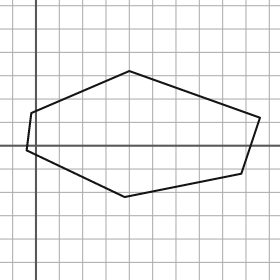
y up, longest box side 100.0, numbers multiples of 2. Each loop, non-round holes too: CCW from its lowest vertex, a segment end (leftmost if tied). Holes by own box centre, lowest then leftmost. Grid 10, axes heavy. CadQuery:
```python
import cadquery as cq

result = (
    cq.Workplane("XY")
    .moveTo(38.0, -22.0)
    .lineTo(88.0, -12.0)
    .lineTo(96.0, 12.0)
    .lineTo(40.0, 32.0)
    .lineTo(-2.0, 14.0)
    .lineTo(-4.0, -2.0)
    .close()
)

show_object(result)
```